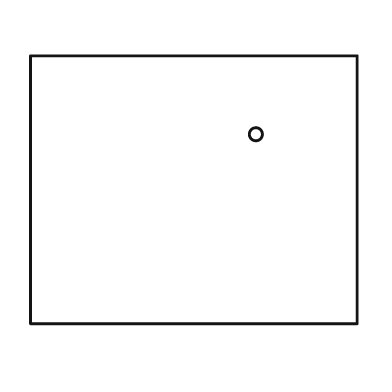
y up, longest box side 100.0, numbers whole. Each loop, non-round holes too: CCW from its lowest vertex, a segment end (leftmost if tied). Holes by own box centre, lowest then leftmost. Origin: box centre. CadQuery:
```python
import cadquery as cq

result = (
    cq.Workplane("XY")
    .moveTo(-50.0, -41.0)
    .lineTo(50.0, -41.0)
    .lineTo(50.0, 41.0)
    .lineTo(-50.0, 41.0)
    .close()
    .moveTo(19.0, 17.0)
    .circle(2.0)
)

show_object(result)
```